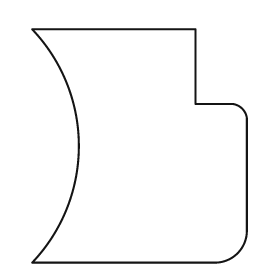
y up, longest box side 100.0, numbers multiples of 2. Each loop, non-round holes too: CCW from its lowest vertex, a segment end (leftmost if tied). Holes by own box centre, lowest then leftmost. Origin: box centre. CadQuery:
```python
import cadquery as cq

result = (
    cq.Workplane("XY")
    .moveTo(-46.0, -50.0)
    .lineTo(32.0, -50.0)
    .threePointArc((42.0, -46.0), (46.0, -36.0))
    .lineTo(46.0, 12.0)
    .threePointArc((44.0, 16.0), (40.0, 18.0))
    .lineTo(24.0, 18.0)
    .lineTo(24.0, 50.0)
    .lineTo(-46.0, 50.0)
    .threePointArc((-26.0, 0.0), (-46.0, -50.0))
    .close()
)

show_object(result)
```